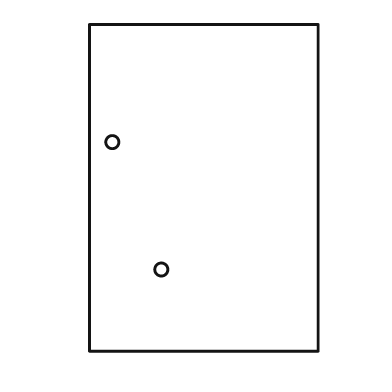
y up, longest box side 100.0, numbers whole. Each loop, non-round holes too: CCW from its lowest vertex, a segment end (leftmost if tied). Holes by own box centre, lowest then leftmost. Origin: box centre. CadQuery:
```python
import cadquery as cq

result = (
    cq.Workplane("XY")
    .moveTo(-35.0, -50.0)
    .lineTo(35.0, -50.0)
    .lineTo(35.0, 50.0)
    .lineTo(-35.0, 50.0)
    .close()
    .moveTo(-13.0, -25.0)
    .circle(2.0)
    .moveTo(-28.0, 14.0)
    .circle(2.0)
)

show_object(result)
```